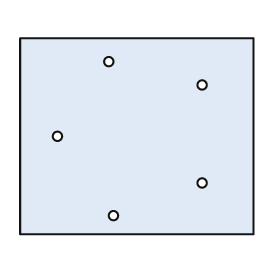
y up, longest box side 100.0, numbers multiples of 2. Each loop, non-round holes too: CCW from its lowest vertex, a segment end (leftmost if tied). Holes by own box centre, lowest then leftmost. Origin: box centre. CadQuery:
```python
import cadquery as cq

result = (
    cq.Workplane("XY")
    .moveTo(-50.0, -42.0)
    .lineTo(50.0, -42.0)
    .lineTo(50.0, 42.0)
    .lineTo(-50.0, 42.0)
    .close()
    .moveTo(-10.0, -34.0)
    .circle(2.0)
    .moveTo(28.0, -20.0)
    .circle(2.0)
    .moveTo(-34.0, 0.0)
    .circle(2.0)
    .moveTo(28.0, 22.0)
    .circle(2.0)
    .moveTo(-12.0, 32.0)
    .circle(2.0)
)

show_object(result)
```